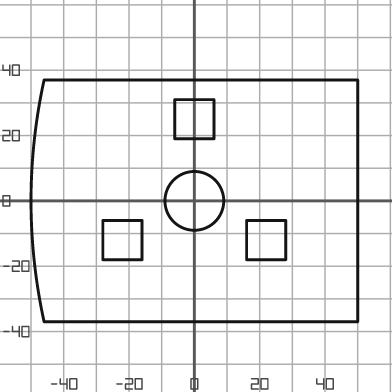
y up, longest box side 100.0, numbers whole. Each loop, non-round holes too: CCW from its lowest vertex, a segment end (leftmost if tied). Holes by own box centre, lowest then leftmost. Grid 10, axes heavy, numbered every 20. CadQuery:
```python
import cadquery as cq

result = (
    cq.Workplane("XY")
    .moveTo(-46.0, -37.0)
    .lineTo(50.0, -37.0)
    .lineTo(50.0, 37.0)
    .lineTo(-46.0, 37.0)
    .threePointArc((-50.0, 0.0), (-46.0, -37.0))
    .close()
    .moveTo(-28.0, -18.0)
    .lineTo(-16.0, -18.0)
    .lineTo(-16.0, -6.0)
    .lineTo(-28.0, -6.0)
    .close()
    .moveTo(16.0, -18.0)
    .lineTo(28.0, -18.0)
    .lineTo(28.0, -6.0)
    .lineTo(16.0, -6.0)
    .close()
    .moveTo(0.0, 0.0)
    .circle(9.0)
    .moveTo(-6.0, 19.0)
    .lineTo(6.0, 19.0)
    .lineTo(6.0, 31.0)
    .lineTo(-6.0, 31.0)
    .close()
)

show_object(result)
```